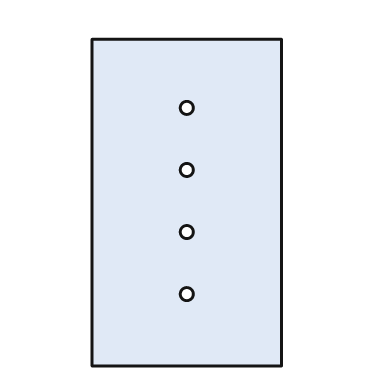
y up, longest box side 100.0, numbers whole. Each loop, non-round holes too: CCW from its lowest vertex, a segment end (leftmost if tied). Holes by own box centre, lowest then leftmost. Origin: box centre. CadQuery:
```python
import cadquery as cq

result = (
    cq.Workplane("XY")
    .moveTo(-29.0, -50.0)
    .lineTo(29.0, -50.0)
    .lineTo(29.0, 50.0)
    .lineTo(-29.0, 50.0)
    .close()
    .moveTo(0.0, -28.0)
    .circle(2.0)
    .moveTo(0.0, -9.0)
    .circle(2.0)
    .moveTo(0.0, 10.0)
    .circle(2.0)
    .moveTo(0.0, 29.0)
    .circle(2.0)
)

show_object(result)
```